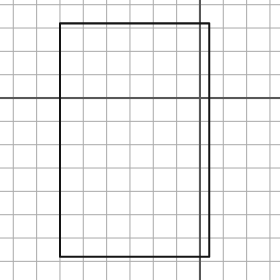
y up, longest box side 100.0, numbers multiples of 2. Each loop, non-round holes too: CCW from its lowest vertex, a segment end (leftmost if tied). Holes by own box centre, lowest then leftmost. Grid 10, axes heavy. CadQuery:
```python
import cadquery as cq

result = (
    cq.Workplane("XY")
    .moveTo(-60.0, -68.0)
    .lineTo(4.0, -68.0)
    .lineTo(4.0, 32.0)
    .lineTo(-60.0, 32.0)
    .close()
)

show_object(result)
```